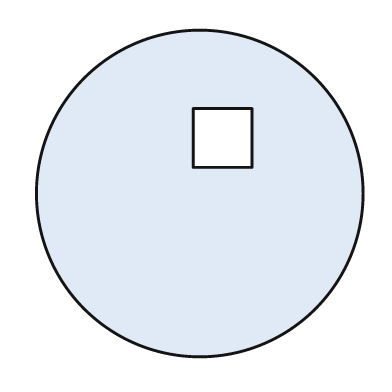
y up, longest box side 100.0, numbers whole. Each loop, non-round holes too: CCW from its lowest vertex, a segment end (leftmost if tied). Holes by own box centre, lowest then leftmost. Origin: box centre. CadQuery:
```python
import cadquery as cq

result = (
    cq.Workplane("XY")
    .moveTo(0.0, 0.0)
    .circle(50.0)
    .moveTo(-2.0, 8.0)
    .lineTo(16.0, 8.0)
    .lineTo(16.0, 26.0)
    .lineTo(-2.0, 26.0)
    .close()
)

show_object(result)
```